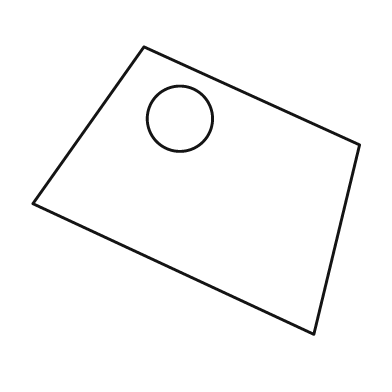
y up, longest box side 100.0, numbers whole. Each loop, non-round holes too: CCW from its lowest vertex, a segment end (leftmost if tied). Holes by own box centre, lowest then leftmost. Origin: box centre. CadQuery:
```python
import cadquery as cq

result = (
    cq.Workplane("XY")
    .moveTo(36.0, -44.0)
    .lineTo(50.0, 14.0)
    .lineTo(-16.0, 44.0)
    .lineTo(-50.0, -4.0)
    .close()
    .moveTo(-5.0, 22.0)
    .circle(10.0)
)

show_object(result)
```